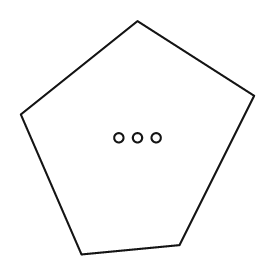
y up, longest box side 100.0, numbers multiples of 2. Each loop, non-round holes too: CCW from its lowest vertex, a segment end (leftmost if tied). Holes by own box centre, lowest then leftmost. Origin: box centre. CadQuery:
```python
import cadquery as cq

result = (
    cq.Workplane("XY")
    .moveTo(-24.0, -50.0)
    .lineTo(18.0, -46.0)
    .lineTo(50.0, 18.0)
    .lineTo(0.0, 50.0)
    .lineTo(-50.0, 10.0)
    .close()
    .moveTo(-8.0, 0.0)
    .circle(2.0)
    .moveTo(0.0, 0.0)
    .circle(2.0)
    .moveTo(8.0, 0.0)
    .circle(2.0)
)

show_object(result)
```